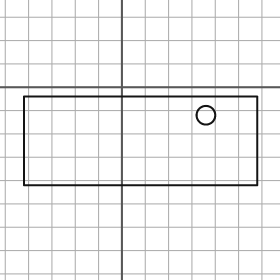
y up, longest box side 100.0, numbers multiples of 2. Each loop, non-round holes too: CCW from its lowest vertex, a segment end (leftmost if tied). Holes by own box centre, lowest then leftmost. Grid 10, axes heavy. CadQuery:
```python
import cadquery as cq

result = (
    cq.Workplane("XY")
    .moveTo(-42.0, -42.0)
    .lineTo(58.0, -42.0)
    .lineTo(58.0, -4.0)
    .lineTo(-42.0, -4.0)
    .close()
    .moveTo(36.0, -12.0)
    .circle(4.0)
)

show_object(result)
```